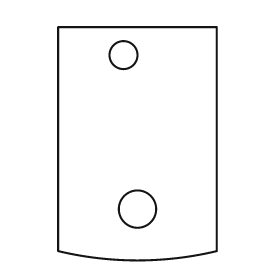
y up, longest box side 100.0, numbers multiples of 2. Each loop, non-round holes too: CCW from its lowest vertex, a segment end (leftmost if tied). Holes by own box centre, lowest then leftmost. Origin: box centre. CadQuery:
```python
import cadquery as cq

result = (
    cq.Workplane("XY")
    .moveTo(-34.0, -46.0)
    .threePointArc((0.0, -50.0), (34.0, -46.0))
    .lineTo(34.0, 50.0)
    .lineTo(-34.0, 50.0)
    .close()
    .moveTo(0.0, -28.0)
    .circle(8.0)
    .moveTo(-6.0, 38.0)
    .circle(6.0)
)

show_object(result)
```